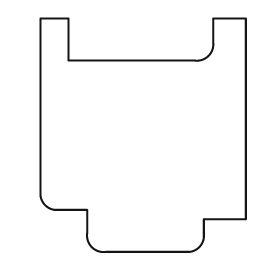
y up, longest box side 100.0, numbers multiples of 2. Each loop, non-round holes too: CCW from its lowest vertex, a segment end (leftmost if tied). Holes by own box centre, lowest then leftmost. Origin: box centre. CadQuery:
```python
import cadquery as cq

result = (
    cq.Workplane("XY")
    .moveTo(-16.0, -50.0)
    .lineTo(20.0, -50.0)
    .threePointArc((24.0, -48.0), (26.0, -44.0))
    .lineTo(26.0, -36.0)
    .lineTo(44.0, -36.0)
    .lineTo(44.0, 50.0)
    .lineTo(30.0, 50.0)
    .lineTo(30.0, 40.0)
    .threePointArc((28.0, 34.0), (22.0, 32.0))
    .lineTo(-32.0, 32.0)
    .lineTo(-32.0, 50.0)
    .lineTo(-44.0, 50.0)
    .lineTo(-44.0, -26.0)
    .threePointArc((-42.0, -30.0), (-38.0, -32.0))
    .lineTo(-24.0, -32.0)
    .lineTo(-24.0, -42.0)
    .threePointArc((-22.0, -48.0), (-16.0, -50.0))
    .close()
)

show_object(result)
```